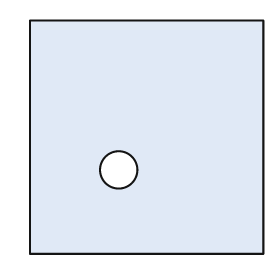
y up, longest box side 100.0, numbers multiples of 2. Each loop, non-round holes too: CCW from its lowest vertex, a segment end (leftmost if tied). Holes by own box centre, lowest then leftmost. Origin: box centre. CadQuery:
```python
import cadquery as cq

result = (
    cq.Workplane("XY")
    .moveTo(-50.0, -50.0)
    .lineTo(50.0, -50.0)
    .lineTo(50.0, 50.0)
    .lineTo(-50.0, 50.0)
    .close()
    .moveTo(-12.0, -14.0)
    .circle(8.0)
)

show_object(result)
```